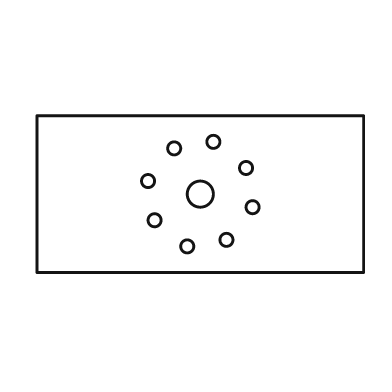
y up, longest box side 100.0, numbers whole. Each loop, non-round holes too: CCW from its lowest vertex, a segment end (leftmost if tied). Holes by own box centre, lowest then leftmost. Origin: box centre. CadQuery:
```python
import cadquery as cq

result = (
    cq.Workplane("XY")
    .moveTo(-50.0, -24.0)
    .lineTo(50.0, -24.0)
    .lineTo(50.0, 24.0)
    .lineTo(-50.0, 24.0)
    .close()
    .moveTo(-4.0, -16.0)
    .circle(2.0)
    .moveTo(8.0, -14.0)
    .circle(2.0)
    .moveTo(-14.0, -8.0)
    .circle(2.0)
    .moveTo(16.0, -4.0)
    .circle(2.0)
    .moveTo(0.0, 0.0)
    .circle(4.0)
    .moveTo(-16.0, 4.0)
    .circle(2.0)
    .moveTo(14.0, 8.0)
    .circle(2.0)
    .moveTo(-8.0, 14.0)
    .circle(2.0)
    .moveTo(4.0, 16.0)
    .circle(2.0)
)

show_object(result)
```